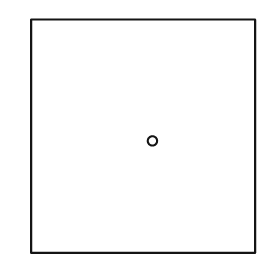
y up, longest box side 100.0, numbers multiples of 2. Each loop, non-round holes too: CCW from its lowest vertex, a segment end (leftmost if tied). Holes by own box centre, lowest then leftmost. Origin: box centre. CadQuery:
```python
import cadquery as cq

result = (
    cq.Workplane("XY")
    .moveTo(-48.0, -50.0)
    .lineTo(48.0, -50.0)
    .lineTo(48.0, 50.0)
    .lineTo(-48.0, 50.0)
    .close()
    .moveTo(4.0, -2.0)
    .circle(2.0)
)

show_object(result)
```